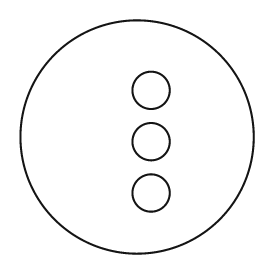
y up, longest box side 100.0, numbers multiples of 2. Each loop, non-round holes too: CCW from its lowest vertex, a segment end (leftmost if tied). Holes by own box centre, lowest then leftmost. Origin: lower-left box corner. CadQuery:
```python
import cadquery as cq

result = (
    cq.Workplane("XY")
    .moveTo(50.0, 50.0)
    .circle(50.0)
    .moveTo(56.0, 26.0)
    .circle(8.0)
    .moveTo(56.0, 48.0)
    .circle(8.0)
    .moveTo(56.0, 70.0)
    .circle(8.0)
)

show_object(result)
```